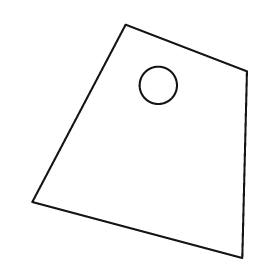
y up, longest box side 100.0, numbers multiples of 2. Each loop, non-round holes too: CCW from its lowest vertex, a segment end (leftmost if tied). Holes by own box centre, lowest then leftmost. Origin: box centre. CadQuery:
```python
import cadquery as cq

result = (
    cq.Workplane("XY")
    .moveTo(44.0, -50.0)
    .lineTo(46.0, 30.0)
    .lineTo(-6.0, 50.0)
    .lineTo(-46.0, -26.0)
    .close()
    .moveTo(8.0, 24.0)
    .circle(8.0)
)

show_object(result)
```